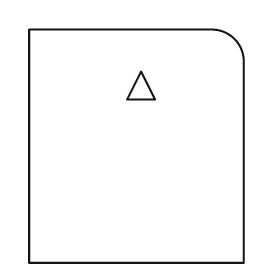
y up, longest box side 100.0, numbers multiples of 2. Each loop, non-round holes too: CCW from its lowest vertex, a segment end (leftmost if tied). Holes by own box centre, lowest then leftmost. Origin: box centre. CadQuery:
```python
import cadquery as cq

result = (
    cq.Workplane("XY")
    .moveTo(-46.0, -50.0)
    .lineTo(46.0, -50.0)
    .lineTo(46.0, 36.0)
    .threePointArc((42.0, 46.0), (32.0, 50.0))
    .lineTo(-46.0, 50.0)
    .close()
    .moveTo(-4.0, 20.0)
    .lineTo(8.0, 20.0)
    .lineTo(2.0, 32.0)
    .close()
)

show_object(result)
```